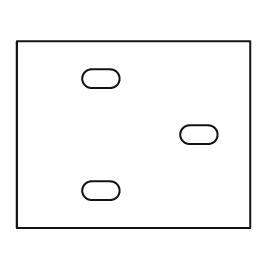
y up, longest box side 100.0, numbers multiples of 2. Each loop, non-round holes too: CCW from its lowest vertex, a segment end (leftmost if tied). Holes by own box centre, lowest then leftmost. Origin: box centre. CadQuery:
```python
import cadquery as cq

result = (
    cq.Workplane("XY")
    .moveTo(-50.0, -40.0)
    .lineTo(50.0, -40.0)
    .lineTo(50.0, 40.0)
    .lineTo(-50.0, 40.0)
    .close()
    .moveTo(-18.0, -28.0)
    .lineTo(-10.0, -28.0)
    .threePointArc((-6.0, -24.0), (-10.0, -20.0))
    .lineTo(-18.0, -20.0)
    .threePointArc((-22.0, -24.0), (-18.0, -28.0))
    .close()
    .moveTo(24.0, -4.0)
    .lineTo(32.0, -4.0)
    .threePointArc((36.0, 0.0), (32.0, 4.0))
    .lineTo(24.0, 4.0)
    .threePointArc((20.0, 0.0), (24.0, -4.0))
    .close()
    .moveTo(-18.0, 20.0)
    .lineTo(-10.0, 20.0)
    .threePointArc((-6.0, 24.0), (-10.0, 28.0))
    .lineTo(-18.0, 28.0)
    .threePointArc((-22.0, 24.0), (-18.0, 20.0))
    .close()
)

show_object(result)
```